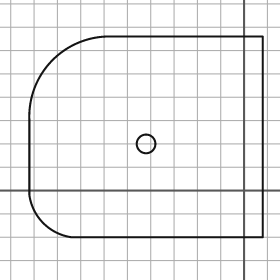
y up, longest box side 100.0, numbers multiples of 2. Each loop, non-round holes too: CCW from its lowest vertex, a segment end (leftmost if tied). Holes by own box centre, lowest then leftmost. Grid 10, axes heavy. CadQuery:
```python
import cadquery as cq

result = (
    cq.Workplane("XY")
    .moveTo(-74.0, -20.0)
    .lineTo(8.0, -20.0)
    .lineTo(8.0, 66.0)
    .lineTo(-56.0, 66.0)
    .threePointArc((-82.0, 56.0), (-92.0, 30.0))
    .lineTo(-92.0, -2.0)
    .threePointArc((-86.0, -14.0), (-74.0, -20.0))
    .close()
    .moveTo(-42.0, 20.0)
    .circle(4.0)
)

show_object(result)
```